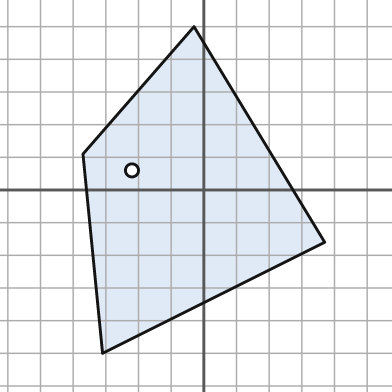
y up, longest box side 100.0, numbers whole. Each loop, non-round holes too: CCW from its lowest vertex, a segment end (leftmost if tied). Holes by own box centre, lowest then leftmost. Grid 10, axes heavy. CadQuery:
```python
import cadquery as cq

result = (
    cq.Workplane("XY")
    .moveTo(-31.0, -50.0)
    .lineTo(37.0, -16.0)
    .lineTo(-3.0, 50.0)
    .lineTo(-37.0, 11.0)
    .close()
    .moveTo(-22.0, 6.0)
    .circle(2.0)
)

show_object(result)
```